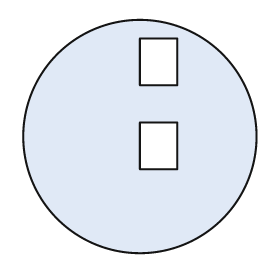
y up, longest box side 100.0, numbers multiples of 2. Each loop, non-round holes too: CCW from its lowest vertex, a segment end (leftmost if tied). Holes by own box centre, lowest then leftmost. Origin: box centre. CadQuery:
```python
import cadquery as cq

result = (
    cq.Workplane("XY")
    .moveTo(0.0, 0.0)
    .circle(50.0)
    .moveTo(0.0, -14.0)
    .lineTo(16.0, -14.0)
    .lineTo(16.0, 6.0)
    .lineTo(0.0, 6.0)
    .close()
    .moveTo(0.0, 22.0)
    .lineTo(16.0, 22.0)
    .lineTo(16.0, 42.0)
    .lineTo(0.0, 42.0)
    .close()
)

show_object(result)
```